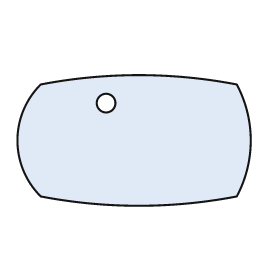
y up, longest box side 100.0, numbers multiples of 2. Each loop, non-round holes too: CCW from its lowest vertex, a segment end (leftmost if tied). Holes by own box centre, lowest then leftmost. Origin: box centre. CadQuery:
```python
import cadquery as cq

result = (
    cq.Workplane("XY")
    .moveTo(-40.0, -24.0)
    .threePointArc((2.0, -28.0), (44.0, -24.0))
    .threePointArc((50.0, 0.0), (44.0, 24.0))
    .threePointArc((2.0, 28.0), (-40.0, 24.0))
    .threePointArc((-50.0, 0.0), (-40.0, -24.0))
    .close()
    .moveTo(-12.0, 16.0)
    .circle(4.0)
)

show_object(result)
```